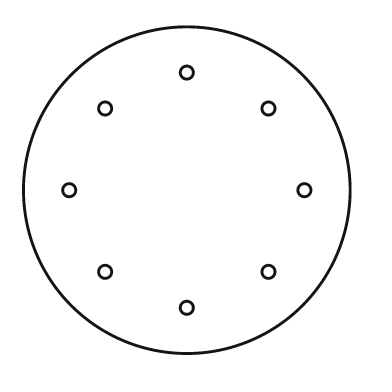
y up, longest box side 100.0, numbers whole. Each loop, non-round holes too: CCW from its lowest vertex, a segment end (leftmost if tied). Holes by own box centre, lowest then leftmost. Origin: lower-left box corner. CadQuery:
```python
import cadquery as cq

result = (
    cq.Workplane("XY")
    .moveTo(50.0, 50.0)
    .circle(50.0)
    .moveTo(50.0, 14.0)
    .circle(2.0)
    .moveTo(25.0, 25.0)
    .circle(2.0)
    .moveTo(75.0, 25.0)
    .circle(2.0)
    .moveTo(14.0, 50.0)
    .circle(2.0)
    .moveTo(86.0, 50.0)
    .circle(2.0)
    .moveTo(25.0, 75.0)
    .circle(2.0)
    .moveTo(75.0, 75.0)
    .circle(2.0)
    .moveTo(50.0, 86.0)
    .circle(2.0)
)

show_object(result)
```